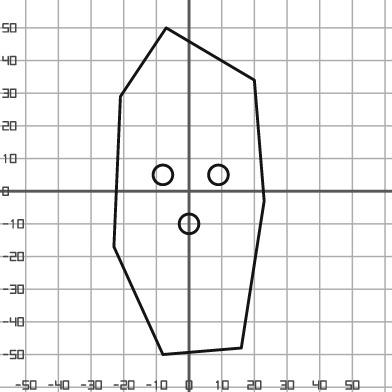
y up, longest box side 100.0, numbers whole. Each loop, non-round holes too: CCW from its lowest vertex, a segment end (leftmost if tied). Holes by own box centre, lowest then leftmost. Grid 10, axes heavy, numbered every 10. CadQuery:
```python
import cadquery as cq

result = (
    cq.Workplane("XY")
    .moveTo(-8.0, -50.0)
    .lineTo(16.0, -48.0)
    .lineTo(23.0, -3.0)
    .lineTo(20.0, 34.0)
    .lineTo(-7.0, 50.0)
    .lineTo(-21.0, 29.0)
    .lineTo(-23.0, -17.0)
    .close()
    .moveTo(0.0, -10.0)
    .circle(3.0)
    .moveTo(-8.0, 5.0)
    .circle(3.0)
    .moveTo(9.0, 5.0)
    .circle(3.0)
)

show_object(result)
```